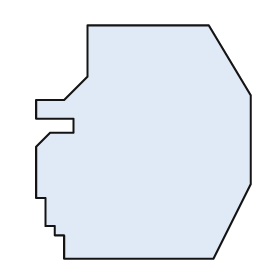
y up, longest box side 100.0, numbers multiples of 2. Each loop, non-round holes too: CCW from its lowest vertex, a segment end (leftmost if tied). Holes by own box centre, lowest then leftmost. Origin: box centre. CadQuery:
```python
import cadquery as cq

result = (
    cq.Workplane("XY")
    .moveTo(-34.0, -50.0)
    .lineTo(30.0, -50.0)
    .lineTo(46.0, -18.0)
    .lineTo(46.0, 20.0)
    .lineTo(28.0, 50.0)
    .lineTo(-24.0, 50.0)
    .lineTo(-24.0, 28.0)
    .lineTo(-34.0, 18.0)
    .lineTo(-46.0, 18.0)
    .lineTo(-46.0, 10.0)
    .lineTo(-30.0, 10.0)
    .lineTo(-30.0, 4.0)
    .lineTo(-40.0, 4.0)
    .lineTo(-46.0, -2.0)
    .lineTo(-46.0, -24.0)
    .lineTo(-42.0, -24.0)
    .lineTo(-42.0, -36.0)
    .lineTo(-38.0, -36.0)
    .lineTo(-38.0, -40.0)
    .lineTo(-34.0, -40.0)
    .close()
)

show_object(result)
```